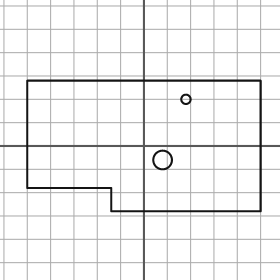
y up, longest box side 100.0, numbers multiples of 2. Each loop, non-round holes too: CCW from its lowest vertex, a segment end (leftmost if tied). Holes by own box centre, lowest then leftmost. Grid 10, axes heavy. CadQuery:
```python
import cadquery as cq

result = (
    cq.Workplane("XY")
    .moveTo(-14.0, -28.0)
    .lineTo(50.0, -28.0)
    .lineTo(50.0, 28.0)
    .lineTo(-50.0, 28.0)
    .lineTo(-50.0, -18.0)
    .lineTo(-14.0, -18.0)
    .close()
    .moveTo(8.0, -6.0)
    .circle(4.0)
    .moveTo(18.0, 20.0)
    .circle(2.0)
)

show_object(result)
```